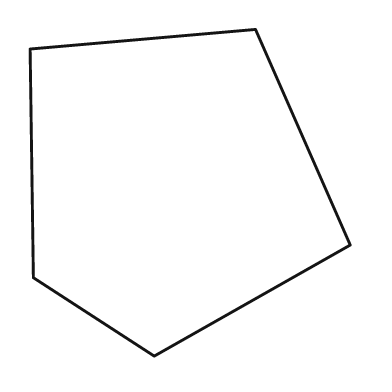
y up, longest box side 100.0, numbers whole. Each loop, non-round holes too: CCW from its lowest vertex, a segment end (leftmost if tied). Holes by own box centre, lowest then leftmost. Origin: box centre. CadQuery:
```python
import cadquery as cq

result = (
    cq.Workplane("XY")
    .moveTo(-11.0, -50.0)
    .lineTo(49.0, -16.0)
    .lineTo(20.0, 50.0)
    .lineTo(-49.0, 44.0)
    .lineTo(-48.0, -26.0)
    .close()
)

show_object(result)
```